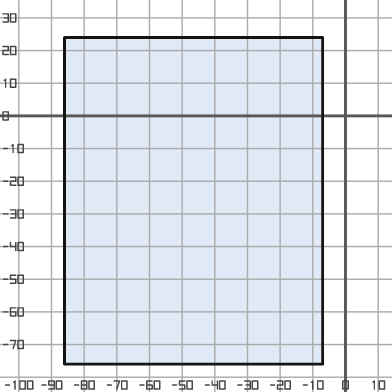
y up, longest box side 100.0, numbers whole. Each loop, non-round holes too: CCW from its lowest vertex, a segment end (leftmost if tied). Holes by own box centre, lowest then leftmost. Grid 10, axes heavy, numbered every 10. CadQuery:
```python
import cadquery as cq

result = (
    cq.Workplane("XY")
    .moveTo(-86.0, -76.0)
    .lineTo(-7.0, -76.0)
    .lineTo(-7.0, 24.0)
    .lineTo(-86.0, 24.0)
    .close()
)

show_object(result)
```